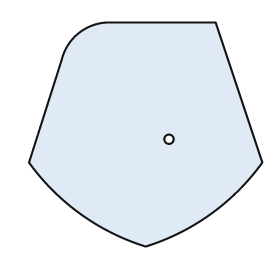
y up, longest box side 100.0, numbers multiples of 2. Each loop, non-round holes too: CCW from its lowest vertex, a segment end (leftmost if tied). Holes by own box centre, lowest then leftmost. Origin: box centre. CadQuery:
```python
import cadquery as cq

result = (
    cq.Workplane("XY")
    .moveTo(0.0, -48.0)
    .threePointArc((28.0, -34.0), (50.0, -12.0))
    .lineTo(30.0, 48.0)
    .lineTo(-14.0, 48.0)
    .threePointArc((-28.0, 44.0), (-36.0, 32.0))
    .lineTo(-50.0, -12.0)
    .threePointArc((-28.0, -34.0), (0.0, -48.0))
    .close()
    .moveTo(10.0, -2.0)
    .circle(2.0)
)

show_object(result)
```